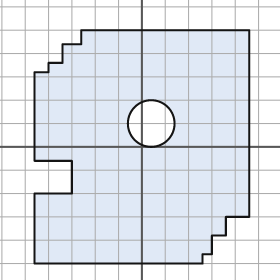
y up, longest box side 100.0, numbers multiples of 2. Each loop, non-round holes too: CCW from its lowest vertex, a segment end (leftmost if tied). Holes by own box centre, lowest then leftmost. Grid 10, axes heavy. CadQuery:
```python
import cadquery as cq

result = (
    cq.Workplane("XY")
    .moveTo(-46.0, -50.0)
    .lineTo(26.0, -50.0)
    .lineTo(26.0, -46.0)
    .lineTo(30.0, -46.0)
    .lineTo(30.0, -38.0)
    .lineTo(36.0, -38.0)
    .lineTo(36.0, -30.0)
    .lineTo(46.0, -30.0)
    .lineTo(46.0, 50.0)
    .lineTo(-26.0, 50.0)
    .lineTo(-26.0, 44.0)
    .lineTo(-34.0, 44.0)
    .lineTo(-34.0, 36.0)
    .lineTo(-40.0, 36.0)
    .lineTo(-40.0, 32.0)
    .lineTo(-46.0, 32.0)
    .lineTo(-46.0, -6.0)
    .lineTo(-30.0, -6.0)
    .lineTo(-30.0, -20.0)
    .lineTo(-46.0, -20.0)
    .close()
    .moveTo(4.0, 10.0)
    .circle(10.0)
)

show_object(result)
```